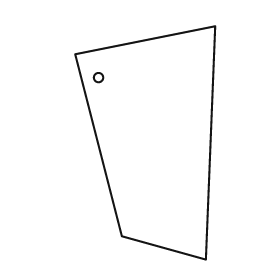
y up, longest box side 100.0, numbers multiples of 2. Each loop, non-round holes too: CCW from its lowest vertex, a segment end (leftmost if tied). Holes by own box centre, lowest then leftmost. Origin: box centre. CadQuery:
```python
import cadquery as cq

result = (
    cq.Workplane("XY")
    .moveTo(26.0, -50.0)
    .lineTo(30.0, 50.0)
    .lineTo(-30.0, 38.0)
    .lineTo(-10.0, -40.0)
    .close()
    .moveTo(-20.0, 28.0)
    .circle(2.0)
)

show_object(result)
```